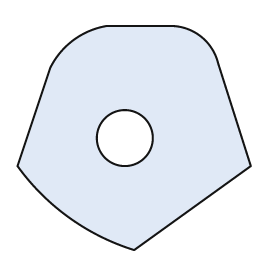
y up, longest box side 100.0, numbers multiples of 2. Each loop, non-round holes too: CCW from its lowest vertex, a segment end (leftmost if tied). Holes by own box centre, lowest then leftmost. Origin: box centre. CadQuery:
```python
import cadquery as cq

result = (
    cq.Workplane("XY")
    .moveTo(0.0, -48.0)
    .lineTo(50.0, -12.0)
    .lineTo(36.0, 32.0)
    .threePointArc((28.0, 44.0), (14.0, 48.0))
    .lineTo(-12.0, 48.0)
    .threePointArc((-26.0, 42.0), (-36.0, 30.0))
    .lineTo(-50.0, -12.0)
    .threePointArc((-28.0, -34.0), (0.0, -48.0))
    .close()
    .moveTo(-4.0, 0.0)
    .circle(12.0)
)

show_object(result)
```